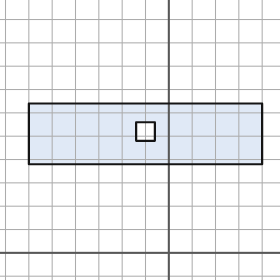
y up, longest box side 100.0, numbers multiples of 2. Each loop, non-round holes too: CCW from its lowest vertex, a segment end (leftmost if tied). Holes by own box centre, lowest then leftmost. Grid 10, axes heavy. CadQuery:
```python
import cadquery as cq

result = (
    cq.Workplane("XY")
    .moveTo(-60.0, 38.0)
    .lineTo(40.0, 38.0)
    .lineTo(40.0, 64.0)
    .lineTo(-60.0, 64.0)
    .close()
    .moveTo(-14.0, 48.0)
    .lineTo(-6.0, 48.0)
    .lineTo(-6.0, 56.0)
    .lineTo(-14.0, 56.0)
    .close()
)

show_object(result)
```